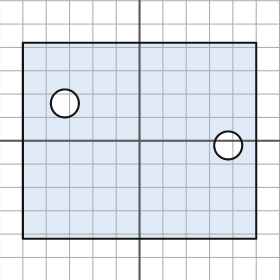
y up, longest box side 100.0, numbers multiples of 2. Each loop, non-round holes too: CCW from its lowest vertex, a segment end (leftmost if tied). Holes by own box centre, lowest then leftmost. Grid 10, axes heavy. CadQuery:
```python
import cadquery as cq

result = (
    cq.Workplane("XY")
    .moveTo(-50.0, -42.0)
    .lineTo(50.0, -42.0)
    .lineTo(50.0, 42.0)
    .lineTo(-50.0, 42.0)
    .close()
    .moveTo(38.0, -2.0)
    .circle(6.0)
    .moveTo(-32.0, 16.0)
    .circle(6.0)
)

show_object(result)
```